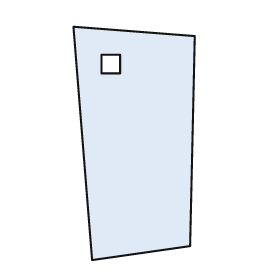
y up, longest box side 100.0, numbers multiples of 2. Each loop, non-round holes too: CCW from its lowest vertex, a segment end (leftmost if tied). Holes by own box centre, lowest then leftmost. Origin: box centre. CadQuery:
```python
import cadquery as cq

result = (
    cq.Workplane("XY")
    .moveTo(-18.0, -50.0)
    .lineTo(24.0, -44.0)
    .lineTo(26.0, 46.0)
    .lineTo(-26.0, 50.0)
    .close()
    .moveTo(-14.0, 30.0)
    .lineTo(-6.0, 30.0)
    .lineTo(-6.0, 38.0)
    .lineTo(-14.0, 38.0)
    .close()
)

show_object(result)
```